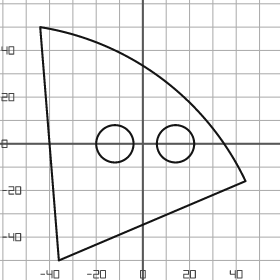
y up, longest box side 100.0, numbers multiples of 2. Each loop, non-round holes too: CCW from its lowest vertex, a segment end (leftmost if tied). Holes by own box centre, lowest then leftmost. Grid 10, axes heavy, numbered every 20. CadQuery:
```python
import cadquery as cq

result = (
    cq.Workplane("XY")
    .moveTo(-36.0, -50.0)
    .lineTo(44.0, -16.0)
    .threePointArc((8.0, 28.0), (-44.0, 50.0))
    .close()
    .moveTo(-12.0, 0.0)
    .circle(8.0)
    .moveTo(14.0, 0.0)
    .circle(8.0)
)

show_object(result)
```